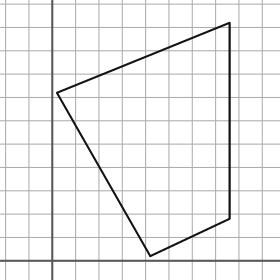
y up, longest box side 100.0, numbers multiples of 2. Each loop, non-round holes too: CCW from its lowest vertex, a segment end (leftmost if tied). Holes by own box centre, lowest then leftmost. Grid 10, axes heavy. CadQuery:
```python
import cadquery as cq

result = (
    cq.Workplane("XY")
    .moveTo(42.0, 2.0)
    .lineTo(76.0, 18.0)
    .lineTo(76.0, 102.0)
    .lineTo(2.0, 72.0)
    .close()
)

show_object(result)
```